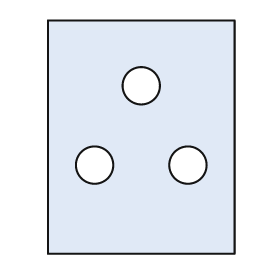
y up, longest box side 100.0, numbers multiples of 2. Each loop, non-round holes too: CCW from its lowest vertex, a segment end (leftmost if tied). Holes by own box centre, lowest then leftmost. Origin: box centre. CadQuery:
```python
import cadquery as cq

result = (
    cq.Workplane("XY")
    .moveTo(-40.0, -50.0)
    .lineTo(40.0, -50.0)
    .lineTo(40.0, 50.0)
    .lineTo(-40.0, 50.0)
    .close()
    .moveTo(-20.0, -12.0)
    .circle(8.0)
    .moveTo(20.0, -12.0)
    .circle(8.0)
    .moveTo(0.0, 22.0)
    .circle(8.0)
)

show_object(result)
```